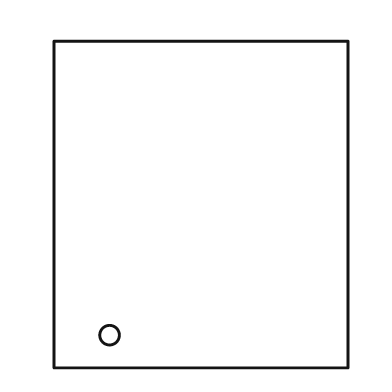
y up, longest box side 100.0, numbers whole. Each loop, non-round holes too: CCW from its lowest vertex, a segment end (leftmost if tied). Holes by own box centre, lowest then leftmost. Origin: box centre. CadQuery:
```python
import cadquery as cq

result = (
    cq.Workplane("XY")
    .moveTo(-45.0, -50.0)
    .lineTo(45.0, -50.0)
    .lineTo(45.0, 50.0)
    .lineTo(-45.0, 50.0)
    .close()
    .moveTo(-28.0, -40.0)
    .circle(3.0)
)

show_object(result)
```